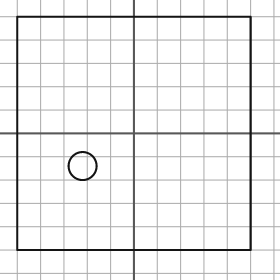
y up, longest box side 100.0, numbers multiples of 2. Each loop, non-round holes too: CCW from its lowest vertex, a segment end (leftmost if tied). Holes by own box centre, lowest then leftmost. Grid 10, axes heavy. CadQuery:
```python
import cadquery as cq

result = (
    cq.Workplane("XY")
    .moveTo(-50.0, -50.0)
    .lineTo(50.0, -50.0)
    .lineTo(50.0, 50.0)
    .lineTo(-50.0, 50.0)
    .close()
    .moveTo(-22.0, -14.0)
    .circle(6.0)
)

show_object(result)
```